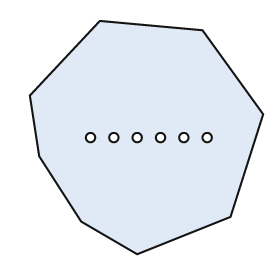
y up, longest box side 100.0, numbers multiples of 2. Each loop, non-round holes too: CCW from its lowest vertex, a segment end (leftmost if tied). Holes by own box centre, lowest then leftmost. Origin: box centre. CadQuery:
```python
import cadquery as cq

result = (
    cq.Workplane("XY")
    .moveTo(-4.0, -50.0)
    .lineTo(36.0, -34.0)
    .lineTo(50.0, 10.0)
    .lineTo(24.0, 46.0)
    .lineTo(-20.0, 50.0)
    .lineTo(-50.0, 18.0)
    .lineTo(-46.0, -8.0)
    .lineTo(-28.0, -36.0)
    .close()
    .moveTo(-24.0, 0.0)
    .circle(2.0)
    .moveTo(-14.0, 0.0)
    .circle(2.0)
    .moveTo(-4.0, 0.0)
    .circle(2.0)
    .moveTo(6.0, 0.0)
    .circle(2.0)
    .moveTo(16.0, 0.0)
    .circle(2.0)
    .moveTo(26.0, 0.0)
    .circle(2.0)
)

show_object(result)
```